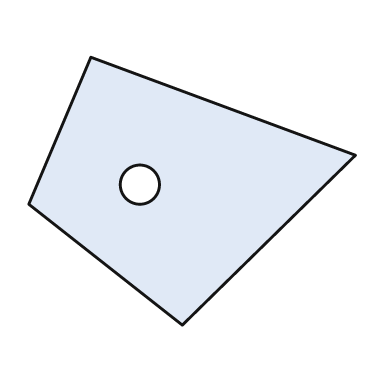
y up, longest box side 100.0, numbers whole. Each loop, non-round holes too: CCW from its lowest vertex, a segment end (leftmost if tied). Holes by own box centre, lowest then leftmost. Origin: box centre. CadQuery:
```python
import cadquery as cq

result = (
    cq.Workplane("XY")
    .moveTo(-3.0, -41.0)
    .lineTo(50.0, 11.0)
    .lineTo(-31.0, 41.0)
    .lineTo(-50.0, -4.0)
    .close()
    .moveTo(-16.0, 2.0)
    .circle(6.0)
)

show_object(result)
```